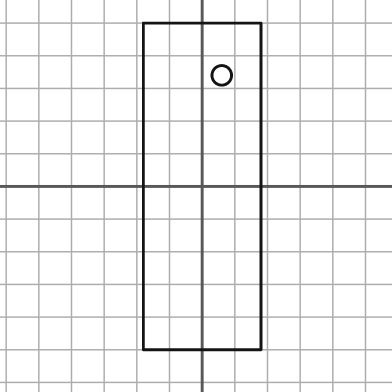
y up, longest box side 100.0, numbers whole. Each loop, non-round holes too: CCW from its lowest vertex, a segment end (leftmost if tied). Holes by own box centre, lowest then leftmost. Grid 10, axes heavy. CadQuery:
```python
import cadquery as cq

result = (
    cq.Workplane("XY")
    .moveTo(-18.0, -50.0)
    .lineTo(18.0, -50.0)
    .lineTo(18.0, 50.0)
    .lineTo(-18.0, 50.0)
    .close()
    .moveTo(6.0, 34.0)
    .circle(3.0)
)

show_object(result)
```